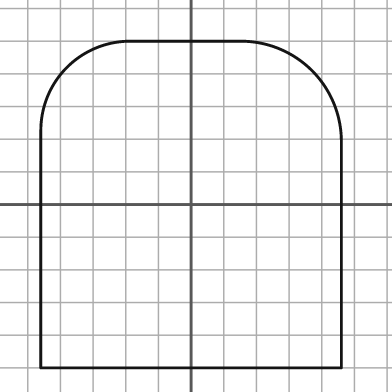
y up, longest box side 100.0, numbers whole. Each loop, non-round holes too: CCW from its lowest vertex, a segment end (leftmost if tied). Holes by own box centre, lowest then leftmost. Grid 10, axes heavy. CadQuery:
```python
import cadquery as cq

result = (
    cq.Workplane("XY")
    .moveTo(-46.0, -50.0)
    .lineTo(46.0, -50.0)
    .lineTo(46.0, 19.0)
    .threePointArc((37.0, 41.0), (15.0, 50.0))
    .lineTo(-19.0, 50.0)
    .threePointArc((-38.0, 42.0), (-46.0, 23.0))
    .close()
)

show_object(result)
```